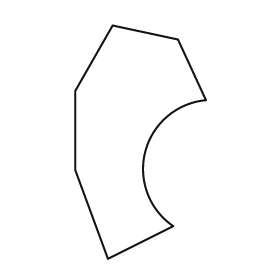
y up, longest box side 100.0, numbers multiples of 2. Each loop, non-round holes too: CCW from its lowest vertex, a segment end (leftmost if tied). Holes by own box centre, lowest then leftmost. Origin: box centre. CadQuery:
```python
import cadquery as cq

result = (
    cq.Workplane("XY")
    .moveTo(-14.0, -50.0)
    .lineTo(14.0, -36.0)
    .threePointArc((2.0, -4.0), (28.0, 18.0))
    .lineTo(16.0, 44.0)
    .lineTo(-12.0, 50.0)
    .lineTo(-28.0, 22.0)
    .lineTo(-28.0, -12.0)
    .close()
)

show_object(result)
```